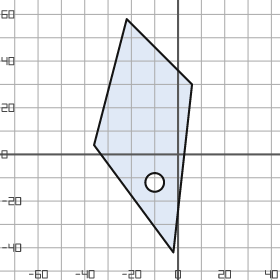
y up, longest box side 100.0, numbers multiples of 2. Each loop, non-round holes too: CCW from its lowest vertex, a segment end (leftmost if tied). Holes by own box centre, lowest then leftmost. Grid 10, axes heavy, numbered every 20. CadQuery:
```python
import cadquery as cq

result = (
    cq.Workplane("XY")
    .moveTo(-2.0, -42.0)
    .lineTo(6.0, 30.0)
    .lineTo(-22.0, 58.0)
    .lineTo(-36.0, 4.0)
    .close()
    .moveTo(-10.0, -12.0)
    .circle(4.0)
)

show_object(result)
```